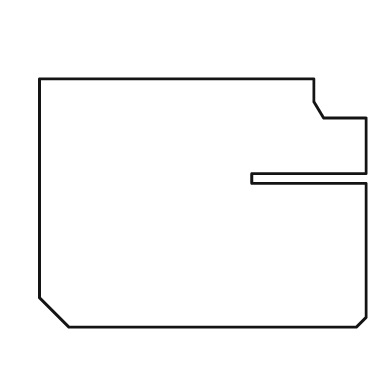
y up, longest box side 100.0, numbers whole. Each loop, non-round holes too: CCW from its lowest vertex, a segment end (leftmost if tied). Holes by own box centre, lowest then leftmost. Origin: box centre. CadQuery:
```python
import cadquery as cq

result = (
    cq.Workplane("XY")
    .moveTo(-41.0, -38.0)
    .lineTo(47.0, -38.0)
    .lineTo(50.0, -35.0)
    .lineTo(50.0, 6.0)
    .lineTo(15.0, 6.0)
    .lineTo(15.0, 9.0)
    .lineTo(50.0, 9.0)
    .lineTo(50.0, 26.0)
    .lineTo(37.0, 26.0)
    .lineTo(34.0, 31.0)
    .lineTo(34.0, 38.0)
    .lineTo(-50.0, 38.0)
    .lineTo(-50.0, -29.0)
    .close()
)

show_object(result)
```